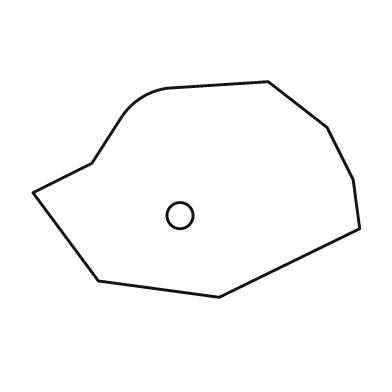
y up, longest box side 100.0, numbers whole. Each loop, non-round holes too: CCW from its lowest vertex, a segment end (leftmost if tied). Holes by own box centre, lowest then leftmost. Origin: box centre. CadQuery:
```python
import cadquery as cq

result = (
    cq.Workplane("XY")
    .moveTo(7.0, -33.0)
    .lineTo(50.0, -12.0)
    .lineTo(48.0, 3.0)
    .lineTo(40.0, 19.0)
    .lineTo(22.0, 33.0)
    .lineTo(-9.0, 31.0)
    .threePointArc((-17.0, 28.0), (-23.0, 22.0))
    .lineTo(-32.0, 8.0)
    .lineTo(-50.0, -1.0)
    .lineTo(-30.0, -28.0)
    .close()
    .moveTo(-5.0, -8.0)
    .circle(4.0)
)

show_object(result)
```